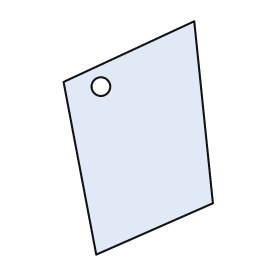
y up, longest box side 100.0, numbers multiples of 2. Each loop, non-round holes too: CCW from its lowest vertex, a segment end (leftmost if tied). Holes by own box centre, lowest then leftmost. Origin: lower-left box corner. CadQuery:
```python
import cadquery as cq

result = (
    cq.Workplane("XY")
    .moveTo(14.0, 0.0)
    .lineTo(64.0, 22.0)
    .lineTo(56.0, 100.0)
    .lineTo(0.0, 74.0)
    .close()
    .moveTo(16.0, 72.0)
    .circle(4.0)
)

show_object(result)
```